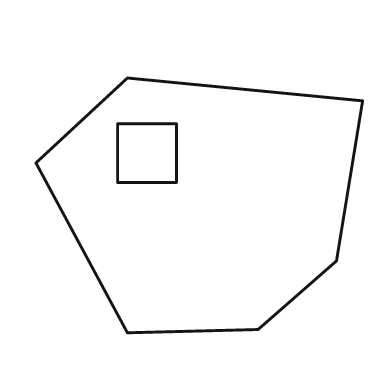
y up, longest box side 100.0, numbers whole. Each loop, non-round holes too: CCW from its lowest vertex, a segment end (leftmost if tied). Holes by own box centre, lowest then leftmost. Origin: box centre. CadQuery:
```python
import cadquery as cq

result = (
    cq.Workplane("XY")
    .moveTo(-22.0, -39.0)
    .lineTo(18.0, -38.0)
    .lineTo(42.0, -17.0)
    .lineTo(50.0, 32.0)
    .lineTo(-22.0, 39.0)
    .lineTo(-50.0, 13.0)
    .close()
    .moveTo(-25.0, 7.0)
    .lineTo(-7.0, 7.0)
    .lineTo(-7.0, 25.0)
    .lineTo(-25.0, 25.0)
    .close()
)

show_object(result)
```